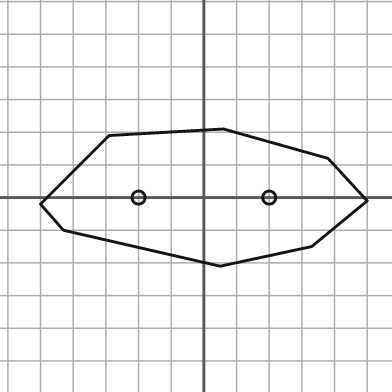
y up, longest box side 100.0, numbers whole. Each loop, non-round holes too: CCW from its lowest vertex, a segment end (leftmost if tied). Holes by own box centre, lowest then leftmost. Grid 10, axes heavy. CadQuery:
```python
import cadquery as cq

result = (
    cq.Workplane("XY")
    .moveTo(5.0, -21.0)
    .lineTo(33.0, -15.0)
    .lineTo(50.0, -1.0)
    .lineTo(38.0, 12.0)
    .lineTo(6.0, 21.0)
    .lineTo(-29.0, 19.0)
    .lineTo(-50.0, -2.0)
    .lineTo(-43.0, -10.0)
    .close()
    .moveTo(-20.0, 0.0)
    .circle(2.0)
    .moveTo(20.0, 0.0)
    .circle(2.0)
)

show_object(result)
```